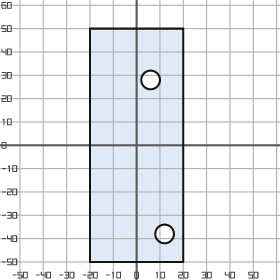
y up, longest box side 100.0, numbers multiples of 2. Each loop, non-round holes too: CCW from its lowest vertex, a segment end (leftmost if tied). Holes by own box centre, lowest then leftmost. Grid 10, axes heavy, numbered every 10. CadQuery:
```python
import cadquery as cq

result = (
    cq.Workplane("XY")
    .moveTo(-20.0, -50.0)
    .lineTo(20.0, -50.0)
    .lineTo(20.0, 50.0)
    .lineTo(-20.0, 50.0)
    .close()
    .moveTo(12.0, -38.0)
    .circle(4.0)
    .moveTo(6.0, 28.0)
    .circle(4.0)
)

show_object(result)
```